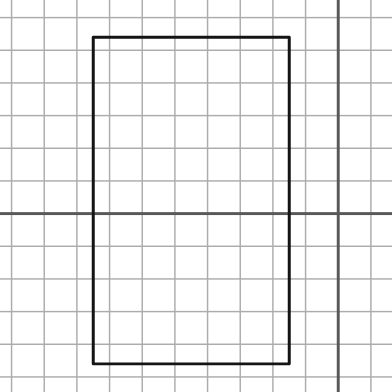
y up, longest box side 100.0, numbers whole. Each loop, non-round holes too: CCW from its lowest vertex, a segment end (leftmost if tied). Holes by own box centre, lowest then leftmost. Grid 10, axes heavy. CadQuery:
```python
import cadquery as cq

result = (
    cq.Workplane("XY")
    .moveTo(-75.0, -46.0)
    .lineTo(-15.0, -46.0)
    .lineTo(-15.0, 54.0)
    .lineTo(-75.0, 54.0)
    .close()
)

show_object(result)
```